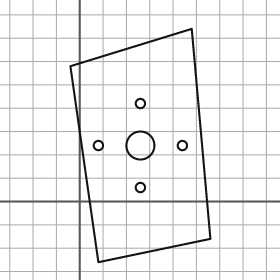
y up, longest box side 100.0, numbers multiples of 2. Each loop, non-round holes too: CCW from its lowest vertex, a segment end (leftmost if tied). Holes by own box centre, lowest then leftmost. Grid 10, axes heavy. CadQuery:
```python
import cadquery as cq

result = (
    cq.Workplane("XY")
    .moveTo(8.0, -26.0)
    .lineTo(56.0, -16.0)
    .lineTo(48.0, 74.0)
    .lineTo(-4.0, 58.0)
    .close()
    .moveTo(26.0, 6.0)
    .circle(2.0)
    .moveTo(8.0, 24.0)
    .circle(2.0)
    .moveTo(26.0, 24.0)
    .circle(6.0)
    .moveTo(44.0, 24.0)
    .circle(2.0)
    .moveTo(26.0, 42.0)
    .circle(2.0)
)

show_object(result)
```